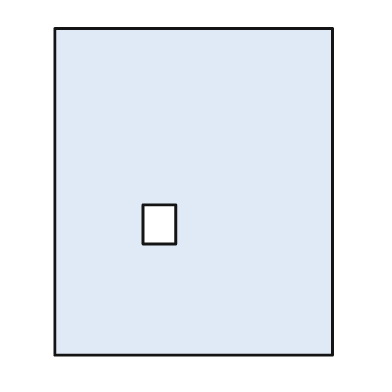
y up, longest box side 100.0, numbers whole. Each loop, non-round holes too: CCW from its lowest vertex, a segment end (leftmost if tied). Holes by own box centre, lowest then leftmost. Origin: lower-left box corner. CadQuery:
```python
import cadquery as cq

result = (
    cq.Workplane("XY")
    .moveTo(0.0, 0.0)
    .lineTo(85.0, 0.0)
    .lineTo(85.0, 100.0)
    .lineTo(0.0, 100.0)
    .close()
    .moveTo(27.0, 34.0)
    .lineTo(37.0, 34.0)
    .lineTo(37.0, 46.0)
    .lineTo(27.0, 46.0)
    .close()
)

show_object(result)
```